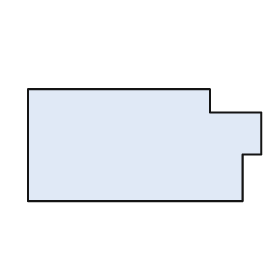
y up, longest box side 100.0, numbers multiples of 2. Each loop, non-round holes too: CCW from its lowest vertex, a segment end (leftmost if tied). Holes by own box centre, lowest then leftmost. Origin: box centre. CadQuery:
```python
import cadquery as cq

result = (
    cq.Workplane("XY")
    .moveTo(-50.0, -24.0)
    .lineTo(42.0, -24.0)
    .lineTo(42.0, -4.0)
    .lineTo(50.0, -4.0)
    .lineTo(50.0, 14.0)
    .lineTo(28.0, 14.0)
    .lineTo(28.0, 24.0)
    .lineTo(-50.0, 24.0)
    .close()
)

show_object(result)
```